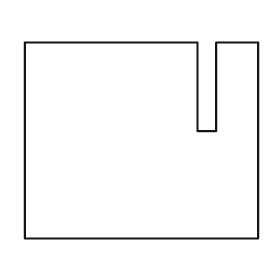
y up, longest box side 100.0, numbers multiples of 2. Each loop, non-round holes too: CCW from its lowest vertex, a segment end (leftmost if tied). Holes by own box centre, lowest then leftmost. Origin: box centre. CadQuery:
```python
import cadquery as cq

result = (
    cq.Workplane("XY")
    .moveTo(-50.0, -42.0)
    .lineTo(50.0, -42.0)
    .lineTo(50.0, 42.0)
    .lineTo(32.0, 42.0)
    .lineTo(32.0, 4.0)
    .lineTo(24.0, 4.0)
    .lineTo(24.0, 42.0)
    .lineTo(-50.0, 42.0)
    .close()
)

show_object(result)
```